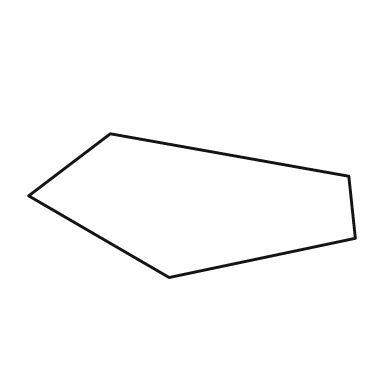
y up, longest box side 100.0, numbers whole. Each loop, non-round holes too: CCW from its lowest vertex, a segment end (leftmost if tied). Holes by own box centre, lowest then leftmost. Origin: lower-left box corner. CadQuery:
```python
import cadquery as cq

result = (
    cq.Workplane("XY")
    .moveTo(43.0, 0.0)
    .lineTo(100.0, 12.0)
    .lineTo(98.0, 31.0)
    .lineTo(25.0, 44.0)
    .lineTo(0.0, 25.0)
    .close()
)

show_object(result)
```